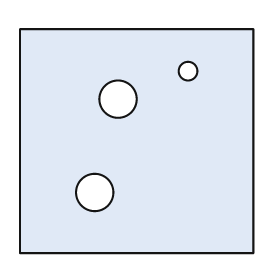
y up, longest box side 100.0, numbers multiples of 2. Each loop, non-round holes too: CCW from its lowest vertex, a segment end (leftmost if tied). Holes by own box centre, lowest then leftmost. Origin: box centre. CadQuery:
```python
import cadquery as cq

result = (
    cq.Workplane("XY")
    .moveTo(-50.0, -48.0)
    .lineTo(50.0, -48.0)
    .lineTo(50.0, 48.0)
    .lineTo(-50.0, 48.0)
    .close()
    .moveTo(-18.0, -22.0)
    .circle(8.0)
    .moveTo(-8.0, 18.0)
    .circle(8.0)
    .moveTo(22.0, 30.0)
    .circle(4.0)
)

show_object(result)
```